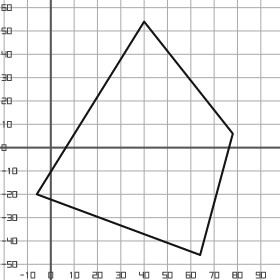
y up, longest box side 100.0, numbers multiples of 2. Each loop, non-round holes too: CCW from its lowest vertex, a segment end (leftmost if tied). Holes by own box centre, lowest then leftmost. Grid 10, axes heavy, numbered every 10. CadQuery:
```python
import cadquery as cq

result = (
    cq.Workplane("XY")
    .moveTo(64.0, -46.0)
    .lineTo(78.0, 6.0)
    .lineTo(40.0, 54.0)
    .lineTo(-6.0, -20.0)
    .close()
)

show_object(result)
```